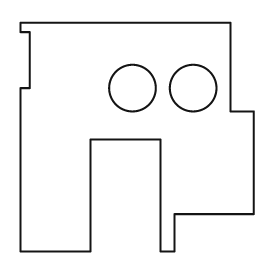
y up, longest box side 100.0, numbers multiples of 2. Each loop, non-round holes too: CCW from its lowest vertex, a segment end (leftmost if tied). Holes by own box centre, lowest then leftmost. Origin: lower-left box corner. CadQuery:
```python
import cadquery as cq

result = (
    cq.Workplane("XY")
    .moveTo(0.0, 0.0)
    .lineTo(30.0, 0.0)
    .lineTo(30.0, 48.0)
    .lineTo(60.0, 48.0)
    .lineTo(60.0, 0.0)
    .lineTo(66.0, 0.0)
    .lineTo(66.0, 16.0)
    .lineTo(100.0, 16.0)
    .lineTo(100.0, 60.0)
    .lineTo(90.0, 60.0)
    .lineTo(90.0, 98.0)
    .lineTo(0.0, 98.0)
    .lineTo(0.0, 94.0)
    .lineTo(4.0, 94.0)
    .lineTo(4.0, 70.0)
    .lineTo(0.0, 70.0)
    .close()
    .moveTo(48.0, 70.0)
    .circle(10.0)
    .moveTo(74.0, 70.0)
    .circle(10.0)
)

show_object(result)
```